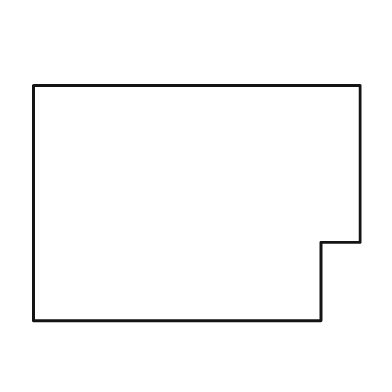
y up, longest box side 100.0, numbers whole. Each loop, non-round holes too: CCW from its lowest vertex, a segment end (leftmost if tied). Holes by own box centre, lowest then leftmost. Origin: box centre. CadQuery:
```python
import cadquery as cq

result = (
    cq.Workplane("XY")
    .moveTo(-50.0, -36.0)
    .lineTo(38.0, -36.0)
    .lineTo(38.0, -12.0)
    .lineTo(50.0, -12.0)
    .lineTo(50.0, 36.0)
    .lineTo(-50.0, 36.0)
    .close()
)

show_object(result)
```